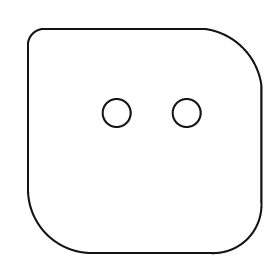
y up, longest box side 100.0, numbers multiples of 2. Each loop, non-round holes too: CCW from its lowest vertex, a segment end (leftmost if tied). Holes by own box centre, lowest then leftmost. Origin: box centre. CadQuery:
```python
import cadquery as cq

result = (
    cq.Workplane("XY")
    .moveTo(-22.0, -48.0)
    .lineTo(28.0, -48.0)
    .threePointArc((44.0, -42.0), (50.0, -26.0))
    .lineTo(50.0, 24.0)
    .threePointArc((42.0, 40.0), (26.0, 48.0))
    .lineTo(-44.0, 48.0)
    .threePointArc((-48.0, 46.0), (-50.0, 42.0))
    .lineTo(-50.0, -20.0)
    .threePointArc((-42.0, -40.0), (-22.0, -48.0))
    .close()
    .moveTo(-12.0, 12.0)
    .circle(6.0)
    .moveTo(18.0, 12.0)
    .circle(6.0)
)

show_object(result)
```